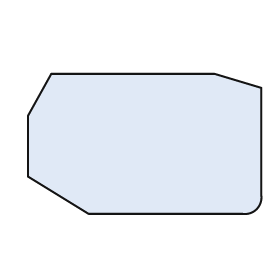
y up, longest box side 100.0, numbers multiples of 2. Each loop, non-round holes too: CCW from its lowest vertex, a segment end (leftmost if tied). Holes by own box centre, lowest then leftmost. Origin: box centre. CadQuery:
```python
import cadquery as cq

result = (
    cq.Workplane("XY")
    .moveTo(-24.0, -30.0)
    .lineTo(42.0, -30.0)
    .threePointArc((48.0, -28.0), (50.0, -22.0))
    .lineTo(50.0, 24.0)
    .lineTo(30.0, 30.0)
    .lineTo(-40.0, 30.0)
    .lineTo(-50.0, 12.0)
    .lineTo(-50.0, -14.0)
    .close()
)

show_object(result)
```